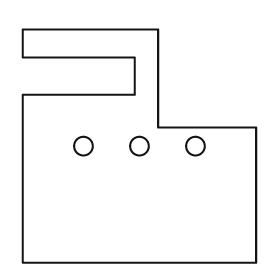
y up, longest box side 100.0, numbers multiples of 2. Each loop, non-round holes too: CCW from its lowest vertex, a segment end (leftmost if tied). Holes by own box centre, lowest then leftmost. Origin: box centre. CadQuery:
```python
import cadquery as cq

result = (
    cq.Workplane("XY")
    .moveTo(-50.0, -50.0)
    .lineTo(50.0, -50.0)
    .lineTo(50.0, 8.0)
    .lineTo(8.0, 8.0)
    .lineTo(8.0, 50.0)
    .lineTo(-50.0, 50.0)
    .lineTo(-50.0, 38.0)
    .lineTo(-2.0, 38.0)
    .lineTo(-2.0, 22.0)
    .lineTo(-50.0, 22.0)
    .close()
    .moveTo(-24.0, 0.0)
    .circle(4.0)
    .moveTo(0.0, 0.0)
    .circle(4.0)
    .moveTo(24.0, 0.0)
    .circle(4.0)
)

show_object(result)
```